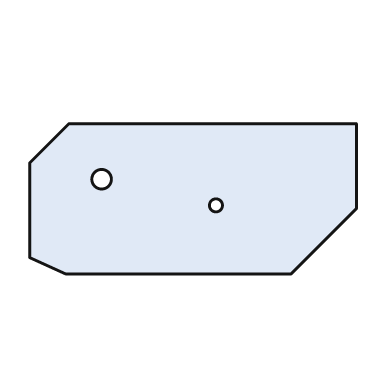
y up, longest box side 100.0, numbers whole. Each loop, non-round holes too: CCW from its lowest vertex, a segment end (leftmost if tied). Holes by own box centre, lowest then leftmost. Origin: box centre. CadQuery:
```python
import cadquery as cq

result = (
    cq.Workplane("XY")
    .moveTo(-39.0, -23.0)
    .lineTo(30.0, -23.0)
    .lineTo(50.0, -3.0)
    .lineTo(50.0, 23.0)
    .lineTo(-38.0, 23.0)
    .lineTo(-50.0, 11.0)
    .lineTo(-50.0, -18.0)
    .close()
    .moveTo(7.0, -2.0)
    .circle(2.0)
    .moveTo(-28.0, 6.0)
    .circle(3.0)
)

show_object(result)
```